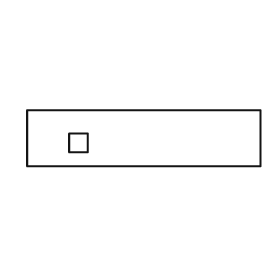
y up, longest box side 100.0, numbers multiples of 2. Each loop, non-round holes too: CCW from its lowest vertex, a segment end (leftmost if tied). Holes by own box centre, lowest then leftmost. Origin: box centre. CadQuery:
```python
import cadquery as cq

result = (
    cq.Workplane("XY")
    .moveTo(-50.0, -12.0)
    .lineTo(50.0, -12.0)
    .lineTo(50.0, 12.0)
    .lineTo(-50.0, 12.0)
    .close()
    .moveTo(-32.0, -6.0)
    .lineTo(-24.0, -6.0)
    .lineTo(-24.0, 2.0)
    .lineTo(-32.0, 2.0)
    .close()
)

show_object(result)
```